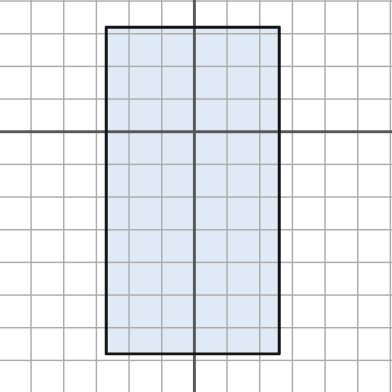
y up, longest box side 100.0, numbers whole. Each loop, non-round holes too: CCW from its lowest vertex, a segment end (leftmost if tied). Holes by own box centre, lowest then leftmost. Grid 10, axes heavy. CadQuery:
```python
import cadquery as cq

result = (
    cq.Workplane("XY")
    .moveTo(-27.0, -68.0)
    .lineTo(26.0, -68.0)
    .lineTo(26.0, 32.0)
    .lineTo(-27.0, 32.0)
    .close()
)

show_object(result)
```